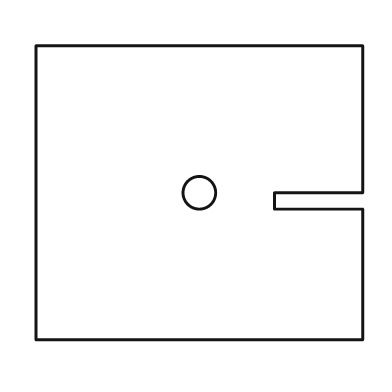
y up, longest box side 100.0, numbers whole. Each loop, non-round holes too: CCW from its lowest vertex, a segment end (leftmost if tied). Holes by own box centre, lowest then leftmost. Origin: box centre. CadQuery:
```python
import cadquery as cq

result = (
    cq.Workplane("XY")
    .moveTo(-50.0, -45.0)
    .lineTo(50.0, -45.0)
    .lineTo(50.0, -5.0)
    .lineTo(23.0, -5.0)
    .lineTo(23.0, 0.0)
    .lineTo(50.0, 0.0)
    .lineTo(50.0, 45.0)
    .lineTo(-50.0, 45.0)
    .close()
    .moveTo(0.0, 0.0)
    .circle(5.0)
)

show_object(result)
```